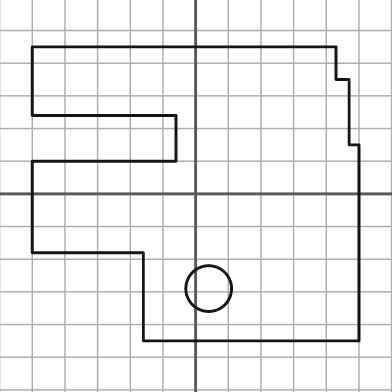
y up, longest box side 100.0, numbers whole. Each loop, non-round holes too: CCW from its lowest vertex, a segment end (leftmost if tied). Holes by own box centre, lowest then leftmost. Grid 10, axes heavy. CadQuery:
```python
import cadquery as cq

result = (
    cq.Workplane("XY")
    .moveTo(-16.0, -45.0)
    .lineTo(50.0, -45.0)
    .lineTo(50.0, 15.0)
    .lineTo(47.0, 15.0)
    .lineTo(47.0, 35.0)
    .lineTo(43.0, 35.0)
    .lineTo(43.0, 45.0)
    .lineTo(-50.0, 45.0)
    .lineTo(-50.0, 24.0)
    .lineTo(-6.0, 24.0)
    .lineTo(-6.0, 10.0)
    .lineTo(-50.0, 10.0)
    .lineTo(-50.0, -18.0)
    .lineTo(-16.0, -18.0)
    .close()
    .moveTo(4.0, -29.0)
    .circle(7.0)
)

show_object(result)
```